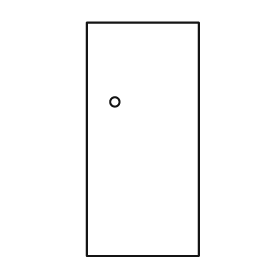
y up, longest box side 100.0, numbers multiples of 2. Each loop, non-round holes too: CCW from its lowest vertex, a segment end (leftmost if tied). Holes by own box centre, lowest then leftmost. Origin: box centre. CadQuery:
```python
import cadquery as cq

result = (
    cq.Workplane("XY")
    .moveTo(-24.0, -50.0)
    .lineTo(24.0, -50.0)
    .lineTo(24.0, 50.0)
    .lineTo(-24.0, 50.0)
    .close()
    .moveTo(-12.0, 16.0)
    .circle(2.0)
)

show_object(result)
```